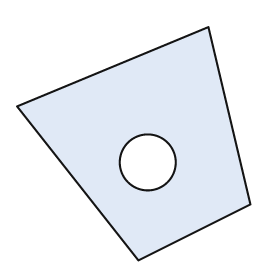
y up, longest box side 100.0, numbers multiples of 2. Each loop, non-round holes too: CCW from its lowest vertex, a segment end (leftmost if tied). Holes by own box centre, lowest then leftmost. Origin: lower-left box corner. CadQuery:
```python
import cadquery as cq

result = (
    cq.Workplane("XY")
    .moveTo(52.0, 0.0)
    .lineTo(100.0, 24.0)
    .lineTo(82.0, 100.0)
    .lineTo(0.0, 66.0)
    .close()
    .moveTo(56.0, 42.0)
    .circle(12.0)
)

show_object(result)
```